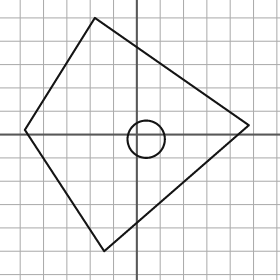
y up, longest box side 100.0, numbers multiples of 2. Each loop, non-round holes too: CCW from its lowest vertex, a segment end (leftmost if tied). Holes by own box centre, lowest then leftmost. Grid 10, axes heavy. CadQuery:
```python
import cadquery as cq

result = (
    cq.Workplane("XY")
    .moveTo(-14.0, -50.0)
    .lineTo(48.0, 4.0)
    .lineTo(-18.0, 50.0)
    .lineTo(-48.0, 2.0)
    .close()
    .moveTo(4.0, -2.0)
    .circle(8.0)
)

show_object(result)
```